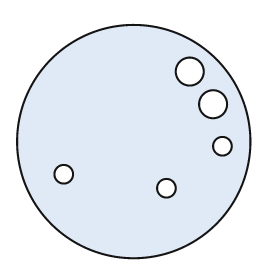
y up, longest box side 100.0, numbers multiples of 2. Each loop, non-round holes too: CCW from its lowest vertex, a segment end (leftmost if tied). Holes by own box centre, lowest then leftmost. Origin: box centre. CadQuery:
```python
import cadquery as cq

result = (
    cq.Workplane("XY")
    .moveTo(0.0, 0.0)
    .circle(50.0)
    .moveTo(14.0, -20.0)
    .circle(4.0)
    .moveTo(-30.0, -14.0)
    .circle(4.0)
    .moveTo(38.0, -2.0)
    .circle(4.0)
    .moveTo(34.0, 16.0)
    .circle(6.0)
    .moveTo(24.0, 30.0)
    .circle(6.0)
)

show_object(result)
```